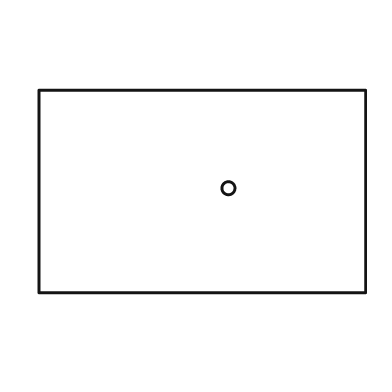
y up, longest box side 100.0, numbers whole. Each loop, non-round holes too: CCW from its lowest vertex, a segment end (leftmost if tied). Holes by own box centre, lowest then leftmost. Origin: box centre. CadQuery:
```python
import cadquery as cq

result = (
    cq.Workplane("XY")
    .moveTo(-50.0, -31.0)
    .lineTo(50.0, -31.0)
    .lineTo(50.0, 31.0)
    .lineTo(-50.0, 31.0)
    .close()
    .moveTo(8.0, 1.0)
    .circle(2.0)
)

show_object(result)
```